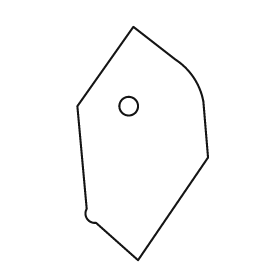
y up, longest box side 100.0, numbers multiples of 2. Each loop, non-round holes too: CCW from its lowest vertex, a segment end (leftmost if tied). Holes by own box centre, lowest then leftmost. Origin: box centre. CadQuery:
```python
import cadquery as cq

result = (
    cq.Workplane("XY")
    .moveTo(-2.0, -50.0)
    .lineTo(28.0, -6.0)
    .lineTo(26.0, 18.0)
    .threePointArc((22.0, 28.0), (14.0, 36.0))
    .lineTo(-4.0, 50.0)
    .lineTo(-28.0, 16.0)
    .lineTo(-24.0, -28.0)
    .threePointArc((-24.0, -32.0), (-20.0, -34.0))
    .close()
    .moveTo(-6.0, 16.0)
    .circle(4.0)
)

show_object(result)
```